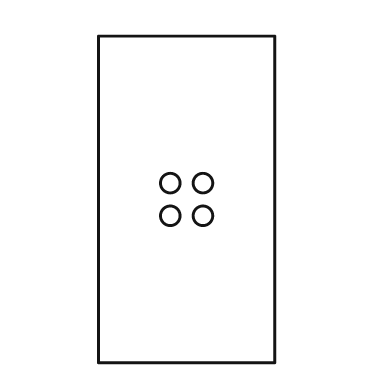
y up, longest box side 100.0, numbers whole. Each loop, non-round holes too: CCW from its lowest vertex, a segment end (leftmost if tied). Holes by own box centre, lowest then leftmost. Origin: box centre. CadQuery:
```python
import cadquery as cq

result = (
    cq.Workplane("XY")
    .moveTo(-27.0, -50.0)
    .lineTo(27.0, -50.0)
    .lineTo(27.0, 50.0)
    .lineTo(-27.0, 50.0)
    .close()
    .moveTo(-5.0, -5.0)
    .circle(3.0)
    .moveTo(5.0, -5.0)
    .circle(3.0)
    .moveTo(-5.0, 5.0)
    .circle(3.0)
    .moveTo(5.0, 5.0)
    .circle(3.0)
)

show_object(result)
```